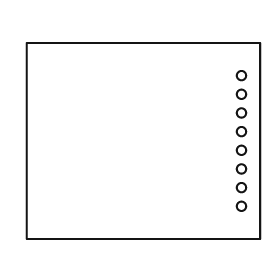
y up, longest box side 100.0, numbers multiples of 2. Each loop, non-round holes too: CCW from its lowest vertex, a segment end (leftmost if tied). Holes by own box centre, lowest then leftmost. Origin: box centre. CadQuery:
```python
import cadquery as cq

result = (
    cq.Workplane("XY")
    .moveTo(-50.0, -42.0)
    .lineTo(50.0, -42.0)
    .lineTo(50.0, 42.0)
    .lineTo(-50.0, 42.0)
    .close()
    .moveTo(42.0, -28.0)
    .circle(2.0)
    .moveTo(42.0, -20.0)
    .circle(2.0)
    .moveTo(42.0, -12.0)
    .circle(2.0)
    .moveTo(42.0, -4.0)
    .circle(2.0)
    .moveTo(42.0, 4.0)
    .circle(2.0)
    .moveTo(42.0, 12.0)
    .circle(2.0)
    .moveTo(42.0, 20.0)
    .circle(2.0)
    .moveTo(42.0, 28.0)
    .circle(2.0)
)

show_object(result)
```